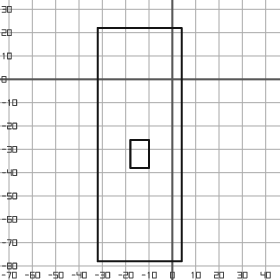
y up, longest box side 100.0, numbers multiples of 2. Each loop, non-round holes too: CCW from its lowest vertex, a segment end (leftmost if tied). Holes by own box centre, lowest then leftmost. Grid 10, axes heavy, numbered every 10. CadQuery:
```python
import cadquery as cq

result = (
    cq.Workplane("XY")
    .moveTo(-32.0, -78.0)
    .lineTo(4.0, -78.0)
    .lineTo(4.0, 22.0)
    .lineTo(-32.0, 22.0)
    .close()
    .moveTo(-18.0, -38.0)
    .lineTo(-10.0, -38.0)
    .lineTo(-10.0, -26.0)
    .lineTo(-18.0, -26.0)
    .close()
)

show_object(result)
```